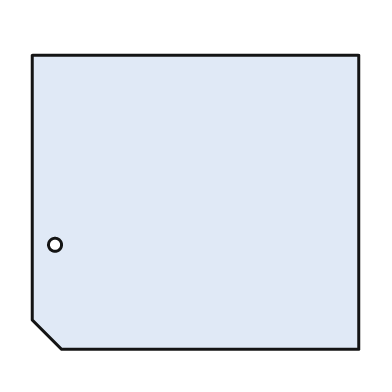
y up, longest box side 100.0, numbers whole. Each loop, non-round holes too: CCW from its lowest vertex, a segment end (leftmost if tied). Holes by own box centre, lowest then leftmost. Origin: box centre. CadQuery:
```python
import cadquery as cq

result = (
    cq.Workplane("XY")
    .moveTo(-41.0, -45.0)
    .lineTo(50.0, -45.0)
    .lineTo(50.0, 45.0)
    .lineTo(-50.0, 45.0)
    .lineTo(-50.0, -36.0)
    .close()
    .moveTo(-43.0, -13.0)
    .circle(2.0)
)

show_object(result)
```